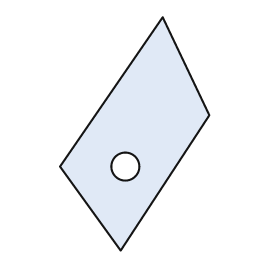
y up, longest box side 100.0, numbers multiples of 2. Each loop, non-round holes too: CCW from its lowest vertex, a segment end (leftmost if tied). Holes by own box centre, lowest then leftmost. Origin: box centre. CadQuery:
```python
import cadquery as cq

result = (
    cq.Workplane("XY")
    .moveTo(-6.0, -50.0)
    .lineTo(32.0, 8.0)
    .lineTo(12.0, 50.0)
    .lineTo(-32.0, -14.0)
    .close()
    .moveTo(-4.0, -14.0)
    .circle(6.0)
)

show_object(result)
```